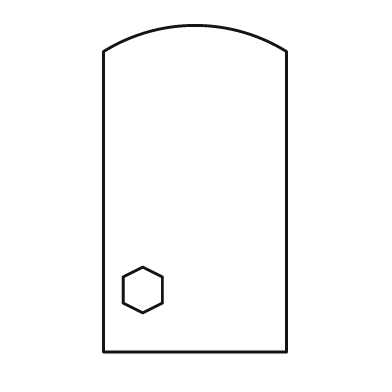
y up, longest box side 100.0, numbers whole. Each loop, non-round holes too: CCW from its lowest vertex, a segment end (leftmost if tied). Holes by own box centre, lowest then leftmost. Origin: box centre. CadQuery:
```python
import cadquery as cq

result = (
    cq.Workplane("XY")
    .moveTo(-28.0, -50.0)
    .lineTo(28.0, -50.0)
    .lineTo(28.0, 42.0)
    .threePointArc((0.0, 50.0), (-28.0, 42.0))
    .close()
    .moveTo(-16.0, -38.0)
    .lineTo(-10.0, -35.0)
    .lineTo(-10.0, -27.0)
    .lineTo(-16.0, -24.0)
    .lineTo(-22.0, -27.0)
    .lineTo(-22.0, -35.0)
    .close()
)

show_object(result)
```